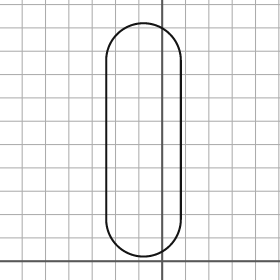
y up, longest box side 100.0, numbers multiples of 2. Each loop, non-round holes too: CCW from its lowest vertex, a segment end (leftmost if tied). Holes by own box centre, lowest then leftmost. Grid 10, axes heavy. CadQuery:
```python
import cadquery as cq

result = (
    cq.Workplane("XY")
    .moveTo(-24.0, 18.0)
    .threePointArc((-8.0, 2.0), (8.0, 18.0))
    .lineTo(8.0, 86.0)
    .threePointArc((-8.0, 102.0), (-24.0, 86.0))
    .close()
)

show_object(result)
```